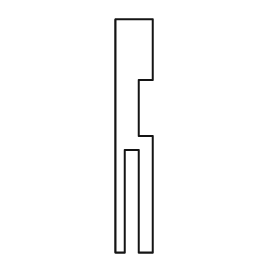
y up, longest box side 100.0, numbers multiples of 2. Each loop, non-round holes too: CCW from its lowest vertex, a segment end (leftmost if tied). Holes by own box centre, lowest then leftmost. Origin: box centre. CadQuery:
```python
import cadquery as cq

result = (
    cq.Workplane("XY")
    .moveTo(-8.0, -50.0)
    .lineTo(-4.0, -50.0)
    .lineTo(-4.0, -6.0)
    .lineTo(2.0, -6.0)
    .lineTo(2.0, -50.0)
    .lineTo(8.0, -50.0)
    .lineTo(8.0, 0.0)
    .lineTo(2.0, 0.0)
    .lineTo(2.0, 24.0)
    .lineTo(8.0, 24.0)
    .lineTo(8.0, 50.0)
    .lineTo(-8.0, 50.0)
    .close()
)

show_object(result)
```